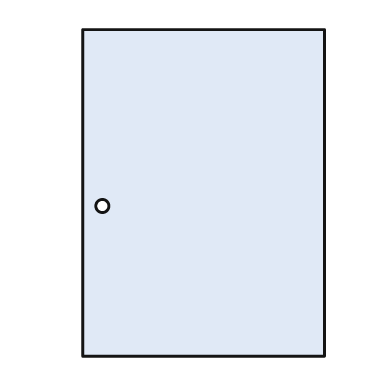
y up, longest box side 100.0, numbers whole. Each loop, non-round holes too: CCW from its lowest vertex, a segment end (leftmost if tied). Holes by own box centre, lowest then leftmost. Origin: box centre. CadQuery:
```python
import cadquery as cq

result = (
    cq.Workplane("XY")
    .moveTo(-37.0, -50.0)
    .lineTo(37.0, -50.0)
    .lineTo(37.0, 50.0)
    .lineTo(-37.0, 50.0)
    .close()
    .moveTo(-31.0, -4.0)
    .circle(2.0)
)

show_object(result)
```